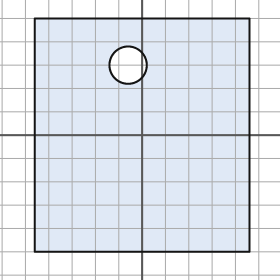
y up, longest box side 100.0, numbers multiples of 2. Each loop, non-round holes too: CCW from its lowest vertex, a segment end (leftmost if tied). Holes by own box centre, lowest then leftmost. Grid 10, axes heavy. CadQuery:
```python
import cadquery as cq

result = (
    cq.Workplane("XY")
    .moveTo(-46.0, -50.0)
    .lineTo(46.0, -50.0)
    .lineTo(46.0, 50.0)
    .lineTo(-46.0, 50.0)
    .close()
    .moveTo(-6.0, 30.0)
    .circle(8.0)
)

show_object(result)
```